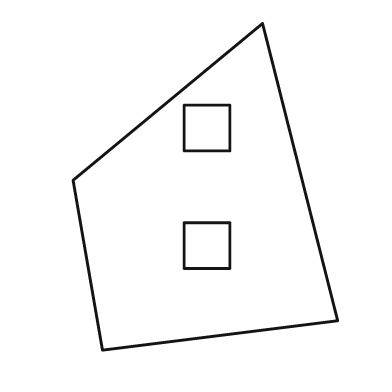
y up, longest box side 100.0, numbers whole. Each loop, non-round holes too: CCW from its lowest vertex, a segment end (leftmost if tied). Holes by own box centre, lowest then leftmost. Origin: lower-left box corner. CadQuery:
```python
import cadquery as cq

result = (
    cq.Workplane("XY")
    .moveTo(9.0, 0.0)
    .lineTo(81.0, 9.0)
    .lineTo(58.0, 100.0)
    .lineTo(0.0, 52.0)
    .close()
    .moveTo(34.0, 25.0)
    .lineTo(48.0, 25.0)
    .lineTo(48.0, 39.0)
    .lineTo(34.0, 39.0)
    .close()
    .moveTo(34.0, 61.0)
    .lineTo(48.0, 61.0)
    .lineTo(48.0, 75.0)
    .lineTo(34.0, 75.0)
    .close()
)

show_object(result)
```